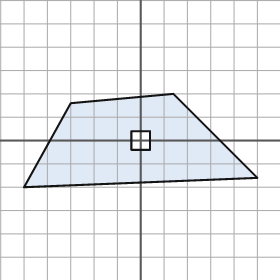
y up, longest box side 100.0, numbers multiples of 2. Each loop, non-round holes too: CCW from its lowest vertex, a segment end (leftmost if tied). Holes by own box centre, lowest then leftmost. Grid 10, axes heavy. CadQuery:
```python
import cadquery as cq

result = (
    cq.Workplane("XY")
    .moveTo(-50.0, -20.0)
    .lineTo(50.0, -16.0)
    .lineTo(14.0, 20.0)
    .lineTo(-30.0, 16.0)
    .close()
    .moveTo(-4.0, -4.0)
    .lineTo(4.0, -4.0)
    .lineTo(4.0, 4.0)
    .lineTo(-4.0, 4.0)
    .close()
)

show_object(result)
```